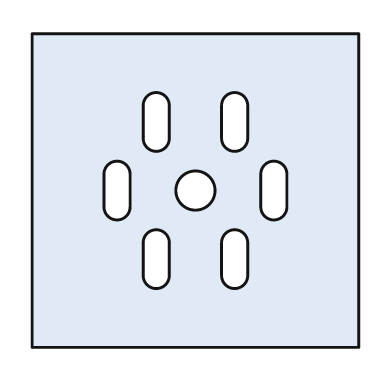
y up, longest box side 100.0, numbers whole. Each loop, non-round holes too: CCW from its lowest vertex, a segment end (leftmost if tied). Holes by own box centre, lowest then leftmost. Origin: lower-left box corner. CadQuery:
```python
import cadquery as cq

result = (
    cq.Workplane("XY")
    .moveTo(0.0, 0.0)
    .lineTo(100.0, 0.0)
    .lineTo(100.0, 96.0)
    .lineTo(0.0, 96.0)
    .close()
    .moveTo(34.0, 22.0)
    .threePointArc((38.0, 18.0), (42.0, 22.0))
    .lineTo(42.0, 32.0)
    .threePointArc((38.0, 36.0), (34.0, 32.0))
    .close()
    .moveTo(58.0, 22.0)
    .threePointArc((62.0, 18.0), (66.0, 22.0))
    .lineTo(66.0, 32.0)
    .threePointArc((62.0, 36.0), (58.0, 32.0))
    .close()
    .moveTo(22.0, 43.0)
    .threePointArc((26.0, 39.0), (30.0, 43.0))
    .lineTo(30.0, 53.0)
    .threePointArc((26.0, 57.0), (22.0, 53.0))
    .close()
    .moveTo(50.0, 48.0)
    .circle(6.0)
    .moveTo(70.0, 43.0)
    .threePointArc((74.0, 39.0), (78.0, 43.0))
    .lineTo(78.0, 53.0)
    .threePointArc((74.0, 57.0), (70.0, 53.0))
    .close()
    .moveTo(34.0, 64.0)
    .threePointArc((38.0, 60.0), (42.0, 64.0))
    .lineTo(42.0, 74.0)
    .threePointArc((38.0, 78.0), (34.0, 74.0))
    .close()
    .moveTo(58.0, 64.0)
    .threePointArc((62.0, 60.0), (66.0, 64.0))
    .lineTo(66.0, 74.0)
    .threePointArc((62.0, 78.0), (58.0, 74.0))
    .close()
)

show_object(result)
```